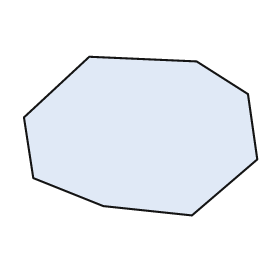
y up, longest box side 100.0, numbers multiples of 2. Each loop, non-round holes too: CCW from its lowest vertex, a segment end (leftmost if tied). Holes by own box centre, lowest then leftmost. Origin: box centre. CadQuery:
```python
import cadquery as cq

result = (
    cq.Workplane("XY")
    .moveTo(22.0, -34.0)
    .lineTo(50.0, -10.0)
    .lineTo(46.0, 18.0)
    .lineTo(24.0, 32.0)
    .lineTo(-22.0, 34.0)
    .lineTo(-50.0, 8.0)
    .lineTo(-46.0, -18.0)
    .lineTo(-16.0, -30.0)
    .close()
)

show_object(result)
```